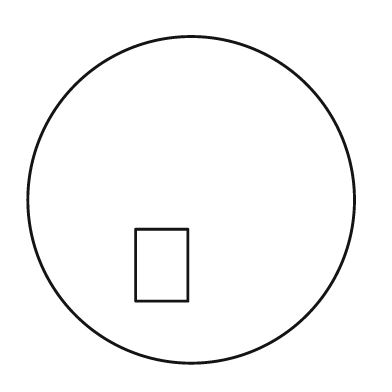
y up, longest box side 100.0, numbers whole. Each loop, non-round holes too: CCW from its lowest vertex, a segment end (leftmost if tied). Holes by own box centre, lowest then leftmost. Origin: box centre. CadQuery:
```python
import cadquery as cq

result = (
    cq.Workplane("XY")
    .moveTo(0.0, 0.0)
    .circle(50.0)
    .moveTo(-17.0, -31.0)
    .lineTo(-1.0, -31.0)
    .lineTo(-1.0, -9.0)
    .lineTo(-17.0, -9.0)
    .close()
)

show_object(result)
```